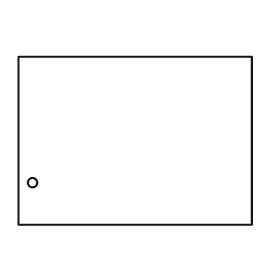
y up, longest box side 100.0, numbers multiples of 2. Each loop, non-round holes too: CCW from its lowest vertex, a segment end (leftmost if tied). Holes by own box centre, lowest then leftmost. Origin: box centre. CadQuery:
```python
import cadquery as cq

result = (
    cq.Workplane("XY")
    .moveTo(-50.0, -36.0)
    .lineTo(50.0, -36.0)
    .lineTo(50.0, 36.0)
    .lineTo(-50.0, 36.0)
    .close()
    .moveTo(-44.0, -18.0)
    .circle(2.0)
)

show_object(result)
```